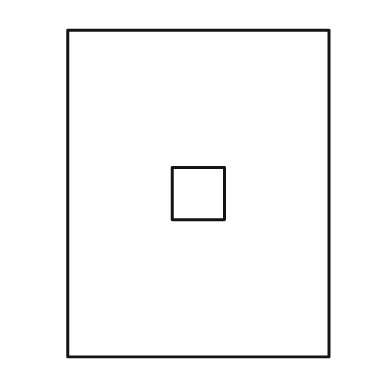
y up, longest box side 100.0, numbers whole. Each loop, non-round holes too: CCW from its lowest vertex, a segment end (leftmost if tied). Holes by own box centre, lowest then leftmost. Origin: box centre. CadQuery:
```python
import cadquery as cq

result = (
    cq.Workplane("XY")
    .moveTo(-40.0, -50.0)
    .lineTo(40.0, -50.0)
    .lineTo(40.0, 50.0)
    .lineTo(-40.0, 50.0)
    .close()
    .moveTo(-8.0, -8.0)
    .lineTo(8.0, -8.0)
    .lineTo(8.0, 8.0)
    .lineTo(-8.0, 8.0)
    .close()
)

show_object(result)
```